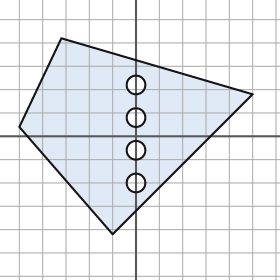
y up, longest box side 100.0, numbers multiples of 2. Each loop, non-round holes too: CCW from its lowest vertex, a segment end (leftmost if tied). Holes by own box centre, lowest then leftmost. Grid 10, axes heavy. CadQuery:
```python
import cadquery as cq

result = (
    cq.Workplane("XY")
    .moveTo(-10.0, -42.0)
    .lineTo(50.0, 18.0)
    .lineTo(-32.0, 42.0)
    .lineTo(-50.0, 4.0)
    .close()
    .moveTo(0.0, -20.0)
    .circle(4.0)
    .moveTo(0.0, -6.0)
    .circle(4.0)
    .moveTo(0.0, 8.0)
    .circle(4.0)
    .moveTo(0.0, 22.0)
    .circle(4.0)
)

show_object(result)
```